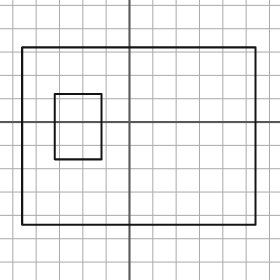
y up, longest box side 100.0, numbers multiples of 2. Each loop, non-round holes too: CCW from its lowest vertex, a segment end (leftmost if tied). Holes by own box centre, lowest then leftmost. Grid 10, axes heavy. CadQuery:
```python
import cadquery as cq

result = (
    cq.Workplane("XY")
    .moveTo(-46.0, -44.0)
    .lineTo(54.0, -44.0)
    .lineTo(54.0, 32.0)
    .lineTo(-46.0, 32.0)
    .close()
    .moveTo(-32.0, -16.0)
    .lineTo(-12.0, -16.0)
    .lineTo(-12.0, 12.0)
    .lineTo(-32.0, 12.0)
    .close()
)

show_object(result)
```